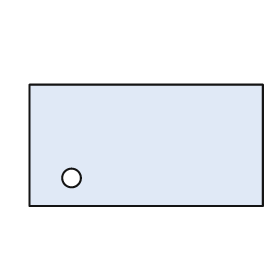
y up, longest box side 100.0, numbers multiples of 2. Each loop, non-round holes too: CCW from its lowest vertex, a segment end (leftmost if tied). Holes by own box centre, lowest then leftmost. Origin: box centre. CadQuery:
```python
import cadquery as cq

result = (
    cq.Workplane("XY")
    .moveTo(-50.0, -26.0)
    .lineTo(50.0, -26.0)
    .lineTo(50.0, 26.0)
    .lineTo(-50.0, 26.0)
    .close()
    .moveTo(-32.0, -14.0)
    .circle(4.0)
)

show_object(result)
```